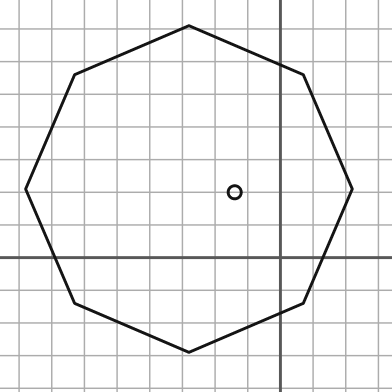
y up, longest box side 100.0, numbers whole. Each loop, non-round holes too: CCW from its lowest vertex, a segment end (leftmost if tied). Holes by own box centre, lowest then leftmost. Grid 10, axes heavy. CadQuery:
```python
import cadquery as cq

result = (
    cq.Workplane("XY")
    .moveTo(-28.0, -29.0)
    .lineTo(7.0, -14.0)
    .lineTo(22.0, 21.0)
    .lineTo(7.0, 56.0)
    .lineTo(-28.0, 71.0)
    .lineTo(-63.0, 56.0)
    .lineTo(-78.0, 21.0)
    .lineTo(-63.0, -14.0)
    .close()
    .moveTo(-14.0, 20.0)
    .circle(2.0)
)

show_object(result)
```